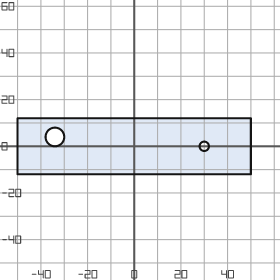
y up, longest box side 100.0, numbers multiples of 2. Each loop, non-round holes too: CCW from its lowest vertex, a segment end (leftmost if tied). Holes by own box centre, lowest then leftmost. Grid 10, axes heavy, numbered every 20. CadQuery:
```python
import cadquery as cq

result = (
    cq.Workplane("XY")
    .moveTo(-50.0, -12.0)
    .lineTo(50.0, -12.0)
    .lineTo(50.0, 12.0)
    .lineTo(-50.0, 12.0)
    .close()
    .moveTo(30.0, 0.0)
    .circle(2.0)
    .moveTo(-34.0, 4.0)
    .circle(4.0)
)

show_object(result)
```